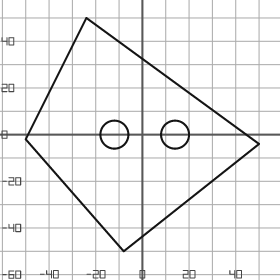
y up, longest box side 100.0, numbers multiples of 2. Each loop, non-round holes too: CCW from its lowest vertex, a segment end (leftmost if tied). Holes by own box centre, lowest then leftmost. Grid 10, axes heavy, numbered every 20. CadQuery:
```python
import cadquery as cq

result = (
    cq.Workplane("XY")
    .moveTo(-8.0, -50.0)
    .lineTo(50.0, -4.0)
    .lineTo(-24.0, 50.0)
    .lineTo(-50.0, -2.0)
    .close()
    .moveTo(-12.0, 0.0)
    .circle(6.0)
    .moveTo(14.0, 0.0)
    .circle(6.0)
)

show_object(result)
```